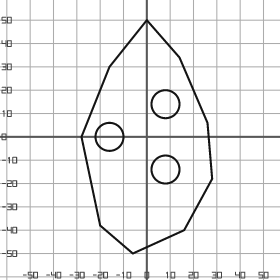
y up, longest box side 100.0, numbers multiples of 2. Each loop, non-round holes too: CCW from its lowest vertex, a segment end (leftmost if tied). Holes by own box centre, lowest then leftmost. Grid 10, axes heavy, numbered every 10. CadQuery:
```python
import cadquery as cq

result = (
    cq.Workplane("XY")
    .moveTo(-6.0, -50.0)
    .lineTo(16.0, -40.0)
    .lineTo(28.0, -18.0)
    .lineTo(26.0, 6.0)
    .lineTo(14.0, 34.0)
    .lineTo(0.0, 50.0)
    .lineTo(-16.0, 30.0)
    .lineTo(-28.0, 0.0)
    .lineTo(-20.0, -38.0)
    .close()
    .moveTo(8.0, -14.0)
    .circle(6.0)
    .moveTo(-16.0, 0.0)
    .circle(6.0)
    .moveTo(8.0, 14.0)
    .circle(6.0)
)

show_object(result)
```